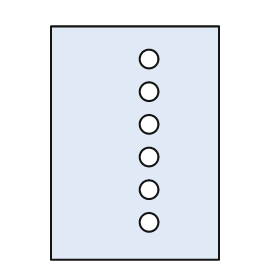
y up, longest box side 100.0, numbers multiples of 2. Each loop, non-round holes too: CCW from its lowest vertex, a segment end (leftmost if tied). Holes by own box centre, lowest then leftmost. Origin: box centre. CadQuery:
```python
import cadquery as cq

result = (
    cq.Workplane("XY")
    .moveTo(-36.0, -50.0)
    .lineTo(36.0, -50.0)
    .lineTo(36.0, 50.0)
    .lineTo(-36.0, 50.0)
    .close()
    .moveTo(6.0, -34.0)
    .circle(4.0)
    .moveTo(6.0, -20.0)
    .circle(4.0)
    .moveTo(6.0, -6.0)
    .circle(4.0)
    .moveTo(6.0, 8.0)
    .circle(4.0)
    .moveTo(6.0, 22.0)
    .circle(4.0)
    .moveTo(6.0, 36.0)
    .circle(4.0)
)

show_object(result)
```